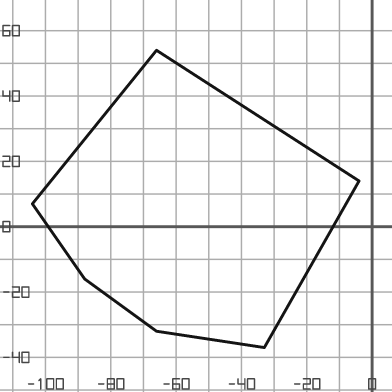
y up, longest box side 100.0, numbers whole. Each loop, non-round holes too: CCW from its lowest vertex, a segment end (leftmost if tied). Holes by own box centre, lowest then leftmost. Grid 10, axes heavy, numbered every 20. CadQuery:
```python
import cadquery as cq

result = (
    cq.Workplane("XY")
    .moveTo(-33.0, -37.0)
    .lineTo(-4.0, 14.0)
    .lineTo(-66.0, 54.0)
    .lineTo(-104.0, 7.0)
    .lineTo(-88.0, -16.0)
    .lineTo(-66.0, -32.0)
    .close()
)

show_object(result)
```